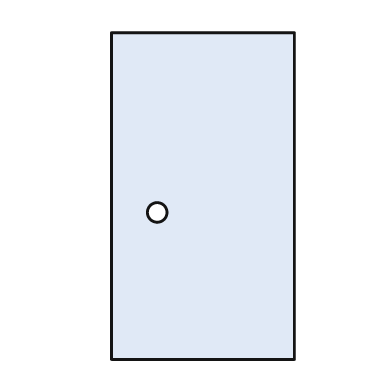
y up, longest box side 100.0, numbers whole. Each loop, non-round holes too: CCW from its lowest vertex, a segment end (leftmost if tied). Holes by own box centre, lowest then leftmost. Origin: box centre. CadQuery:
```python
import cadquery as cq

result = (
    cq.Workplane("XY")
    .moveTo(-28.0, -50.0)
    .lineTo(28.0, -50.0)
    .lineTo(28.0, 50.0)
    .lineTo(-28.0, 50.0)
    .close()
    .moveTo(-14.0, -5.0)
    .circle(3.0)
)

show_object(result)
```